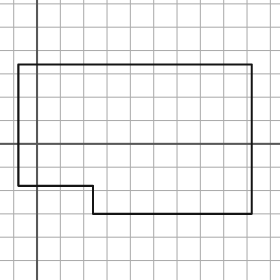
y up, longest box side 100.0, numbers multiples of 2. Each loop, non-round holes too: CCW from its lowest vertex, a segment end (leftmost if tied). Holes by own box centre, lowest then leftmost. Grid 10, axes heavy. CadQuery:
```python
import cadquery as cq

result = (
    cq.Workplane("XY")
    .moveTo(24.0, -30.0)
    .lineTo(92.0, -30.0)
    .lineTo(92.0, 34.0)
    .lineTo(-8.0, 34.0)
    .lineTo(-8.0, -18.0)
    .lineTo(24.0, -18.0)
    .close()
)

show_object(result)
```